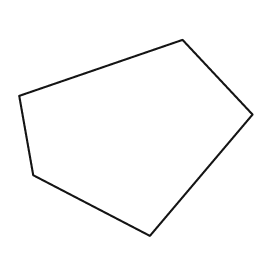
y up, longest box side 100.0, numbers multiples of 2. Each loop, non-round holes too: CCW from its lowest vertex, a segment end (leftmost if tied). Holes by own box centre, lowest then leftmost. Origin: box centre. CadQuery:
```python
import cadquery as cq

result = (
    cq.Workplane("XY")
    .moveTo(6.0, -42.0)
    .lineTo(50.0, 10.0)
    .lineTo(20.0, 42.0)
    .lineTo(-50.0, 18.0)
    .lineTo(-44.0, -16.0)
    .close()
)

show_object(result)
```